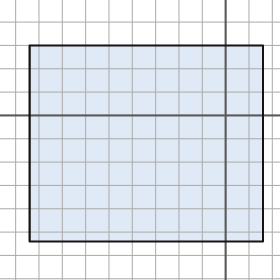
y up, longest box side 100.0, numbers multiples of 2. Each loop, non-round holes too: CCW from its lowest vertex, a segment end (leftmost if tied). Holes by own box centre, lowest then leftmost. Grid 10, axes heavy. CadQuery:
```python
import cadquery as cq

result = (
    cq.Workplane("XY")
    .moveTo(-84.0, -54.0)
    .lineTo(16.0, -54.0)
    .lineTo(16.0, 30.0)
    .lineTo(-84.0, 30.0)
    .close()
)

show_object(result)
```